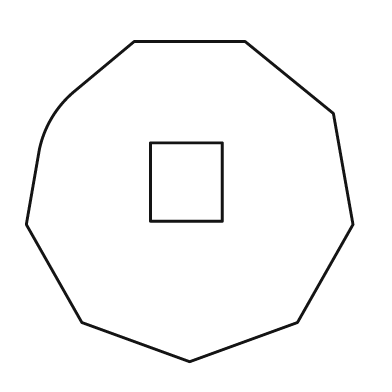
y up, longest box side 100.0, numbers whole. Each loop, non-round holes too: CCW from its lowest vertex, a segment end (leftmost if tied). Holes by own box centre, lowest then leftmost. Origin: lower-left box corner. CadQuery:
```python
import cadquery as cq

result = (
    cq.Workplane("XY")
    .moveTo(50.0, 0.0)
    .lineTo(83.0, 12.0)
    .lineTo(100.0, 42.0)
    .lineTo(94.0, 76.0)
    .lineTo(67.0, 98.0)
    .lineTo(33.0, 98.0)
    .lineTo(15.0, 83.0)
    .threePointArc((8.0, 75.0), (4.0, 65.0))
    .lineTo(0.0, 42.0)
    .lineTo(17.0, 12.0)
    .close()
    .moveTo(38.0, 43.0)
    .lineTo(60.0, 43.0)
    .lineTo(60.0, 67.0)
    .lineTo(38.0, 67.0)
    .close()
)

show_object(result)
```